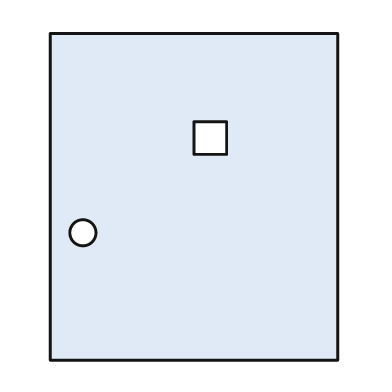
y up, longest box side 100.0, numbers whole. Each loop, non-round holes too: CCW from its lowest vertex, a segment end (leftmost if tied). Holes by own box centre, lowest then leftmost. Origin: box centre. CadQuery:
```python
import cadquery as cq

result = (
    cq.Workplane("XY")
    .moveTo(-44.0, -50.0)
    .lineTo(44.0, -50.0)
    .lineTo(44.0, 50.0)
    .lineTo(-44.0, 50.0)
    .close()
    .moveTo(-34.0, -11.0)
    .circle(4.0)
    .moveTo(0.0, 13.0)
    .lineTo(10.0, 13.0)
    .lineTo(10.0, 23.0)
    .lineTo(0.0, 23.0)
    .close()
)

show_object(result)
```